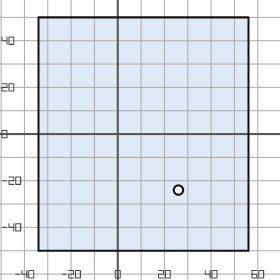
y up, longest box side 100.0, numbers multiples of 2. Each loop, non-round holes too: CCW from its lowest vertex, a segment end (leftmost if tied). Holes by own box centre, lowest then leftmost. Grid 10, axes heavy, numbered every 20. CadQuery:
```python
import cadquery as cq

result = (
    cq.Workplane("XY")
    .moveTo(-34.0, -50.0)
    .lineTo(56.0, -50.0)
    .lineTo(56.0, 50.0)
    .lineTo(-34.0, 50.0)
    .close()
    .moveTo(26.0, -24.0)
    .circle(2.0)
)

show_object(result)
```